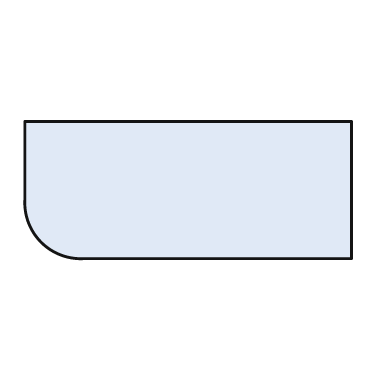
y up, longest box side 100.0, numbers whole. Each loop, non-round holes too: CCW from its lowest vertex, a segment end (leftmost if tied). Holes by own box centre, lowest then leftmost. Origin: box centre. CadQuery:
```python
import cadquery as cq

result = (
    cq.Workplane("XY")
    .moveTo(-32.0, -21.0)
    .lineTo(50.0, -21.0)
    .lineTo(50.0, 21.0)
    .lineTo(-50.0, 21.0)
    .lineTo(-50.0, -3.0)
    .threePointArc((-45.0, -16.0), (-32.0, -21.0))
    .close()
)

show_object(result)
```